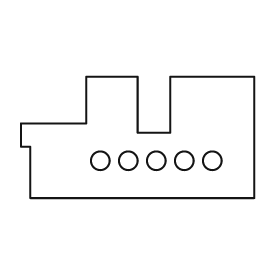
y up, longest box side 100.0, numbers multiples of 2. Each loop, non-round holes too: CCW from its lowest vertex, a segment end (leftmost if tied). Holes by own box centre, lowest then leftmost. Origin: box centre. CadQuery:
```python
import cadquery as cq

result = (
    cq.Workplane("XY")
    .moveTo(-46.0, -26.0)
    .lineTo(50.0, -26.0)
    .lineTo(50.0, 26.0)
    .lineTo(14.0, 26.0)
    .lineTo(14.0, 2.0)
    .lineTo(0.0, 2.0)
    .lineTo(0.0, 26.0)
    .lineTo(-22.0, 26.0)
    .lineTo(-22.0, 6.0)
    .lineTo(-50.0, 6.0)
    .lineTo(-50.0, -4.0)
    .lineTo(-46.0, -4.0)
    .close()
    .moveTo(-16.0, -10.0)
    .circle(4.0)
    .moveTo(-4.0, -10.0)
    .circle(4.0)
    .moveTo(8.0, -10.0)
    .circle(4.0)
    .moveTo(20.0, -10.0)
    .circle(4.0)
    .moveTo(32.0, -10.0)
    .circle(4.0)
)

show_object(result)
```